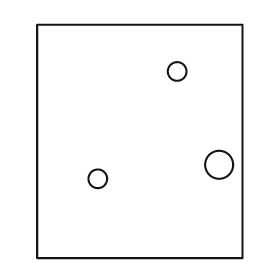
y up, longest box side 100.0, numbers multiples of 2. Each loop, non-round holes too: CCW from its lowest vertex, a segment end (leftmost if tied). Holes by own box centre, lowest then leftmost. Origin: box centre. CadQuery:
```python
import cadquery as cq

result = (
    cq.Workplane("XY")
    .moveTo(-44.0, -50.0)
    .lineTo(44.0, -50.0)
    .lineTo(44.0, 50.0)
    .lineTo(-44.0, 50.0)
    .close()
    .moveTo(-18.0, -16.0)
    .circle(4.0)
    .moveTo(34.0, -10.0)
    .circle(6.0)
    .moveTo(16.0, 30.0)
    .circle(4.0)
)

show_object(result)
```